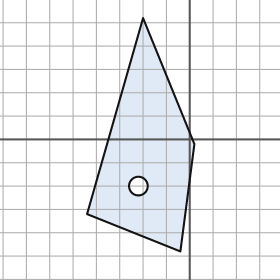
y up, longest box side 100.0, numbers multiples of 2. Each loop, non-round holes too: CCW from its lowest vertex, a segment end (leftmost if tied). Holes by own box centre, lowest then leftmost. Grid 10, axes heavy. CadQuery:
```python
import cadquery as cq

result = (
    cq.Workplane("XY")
    .moveTo(-4.0, -48.0)
    .lineTo(2.0, -2.0)
    .lineTo(-20.0, 52.0)
    .lineTo(-44.0, -32.0)
    .close()
    .moveTo(-22.0, -20.0)
    .circle(4.0)
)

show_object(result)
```